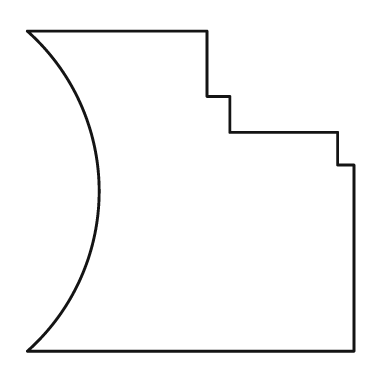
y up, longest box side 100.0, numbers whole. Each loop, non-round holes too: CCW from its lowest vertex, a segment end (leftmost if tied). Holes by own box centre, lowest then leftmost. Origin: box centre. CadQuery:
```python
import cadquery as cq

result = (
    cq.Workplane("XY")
    .moveTo(-50.0, -49.0)
    .lineTo(50.0, -49.0)
    .lineTo(50.0, 8.0)
    .lineTo(45.0, 8.0)
    .lineTo(45.0, 18.0)
    .lineTo(12.0, 18.0)
    .lineTo(12.0, 29.0)
    .lineTo(5.0, 29.0)
    .lineTo(5.0, 49.0)
    .lineTo(-50.0, 49.0)
    .threePointArc((-28.0, 0.0), (-50.0, -49.0))
    .close()
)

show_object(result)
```